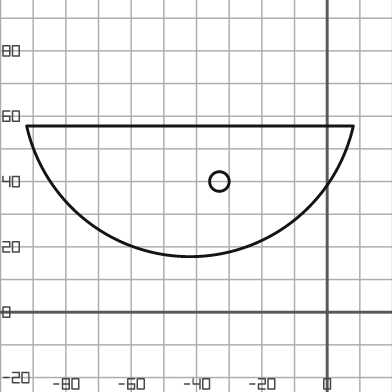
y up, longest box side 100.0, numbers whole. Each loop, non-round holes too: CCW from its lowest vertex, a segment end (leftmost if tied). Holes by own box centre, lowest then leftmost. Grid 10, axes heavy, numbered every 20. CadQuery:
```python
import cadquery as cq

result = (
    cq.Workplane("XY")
    .moveTo(-92.0, 57.0)
    .threePointArc((-42.0, 17.0), (8.0, 57.0))
    .close()
    .moveTo(-33.0, 40.0)
    .circle(3.0)
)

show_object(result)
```